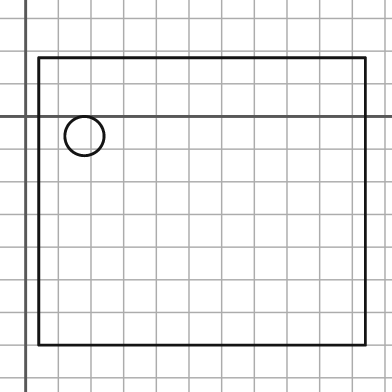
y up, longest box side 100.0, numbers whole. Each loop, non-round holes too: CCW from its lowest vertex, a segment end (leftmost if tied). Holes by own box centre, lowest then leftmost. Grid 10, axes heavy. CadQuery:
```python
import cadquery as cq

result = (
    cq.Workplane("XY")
    .moveTo(4.0, -70.0)
    .lineTo(104.0, -70.0)
    .lineTo(104.0, 18.0)
    .lineTo(4.0, 18.0)
    .close()
    .moveTo(18.0, -6.0)
    .circle(6.0)
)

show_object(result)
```